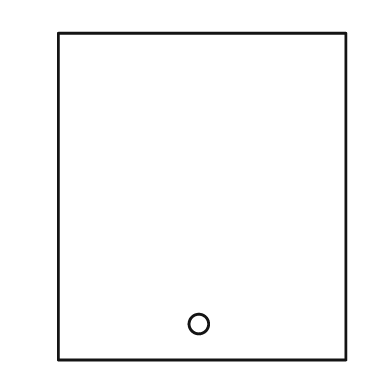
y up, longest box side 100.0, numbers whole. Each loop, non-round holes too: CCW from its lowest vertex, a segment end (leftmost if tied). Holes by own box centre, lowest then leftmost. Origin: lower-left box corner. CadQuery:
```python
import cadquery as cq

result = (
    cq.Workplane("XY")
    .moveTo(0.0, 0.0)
    .lineTo(88.0, 0.0)
    .lineTo(88.0, 100.0)
    .lineTo(0.0, 100.0)
    .close()
    .moveTo(43.0, 11.0)
    .circle(3.0)
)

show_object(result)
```